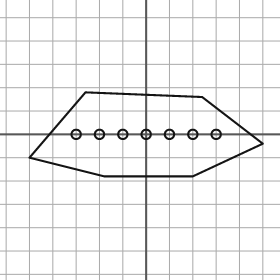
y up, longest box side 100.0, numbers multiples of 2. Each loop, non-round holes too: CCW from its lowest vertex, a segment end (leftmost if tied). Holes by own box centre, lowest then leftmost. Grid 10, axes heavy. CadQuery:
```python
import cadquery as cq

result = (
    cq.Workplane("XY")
    .moveTo(-18.0, -18.0)
    .lineTo(20.0, -18.0)
    .lineTo(50.0, -4.0)
    .lineTo(24.0, 16.0)
    .lineTo(-26.0, 18.0)
    .lineTo(-50.0, -10.0)
    .close()
    .moveTo(-30.0, 0.0)
    .circle(2.0)
    .moveTo(-20.0, 0.0)
    .circle(2.0)
    .moveTo(-10.0, 0.0)
    .circle(2.0)
    .moveTo(0.0, 0.0)
    .circle(2.0)
    .moveTo(10.0, 0.0)
    .circle(2.0)
    .moveTo(20.0, 0.0)
    .circle(2.0)
    .moveTo(30.0, 0.0)
    .circle(2.0)
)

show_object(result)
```